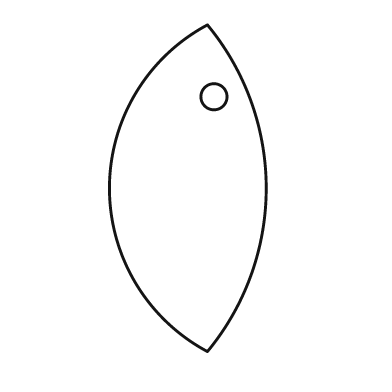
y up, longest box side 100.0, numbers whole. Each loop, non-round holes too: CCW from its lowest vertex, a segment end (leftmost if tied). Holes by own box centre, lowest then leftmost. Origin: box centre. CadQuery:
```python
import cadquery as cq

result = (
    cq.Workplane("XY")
    .moveTo(6.0, -50.0)
    .threePointArc((24.0, 0.0), (6.0, 50.0))
    .threePointArc((-24.0, 0.0), (6.0, -50.0))
    .close()
    .moveTo(8.0, 28.0)
    .circle(4.0)
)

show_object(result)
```